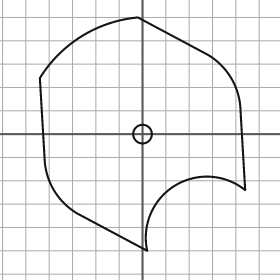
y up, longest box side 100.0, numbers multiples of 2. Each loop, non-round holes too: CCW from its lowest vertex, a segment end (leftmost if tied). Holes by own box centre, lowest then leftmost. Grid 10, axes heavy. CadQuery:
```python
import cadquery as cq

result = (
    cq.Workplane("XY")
    .moveTo(2.0, -50.0)
    .threePointArc((14.0, -22.0), (44.0, -24.0))
    .lineTo(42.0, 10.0)
    .threePointArc((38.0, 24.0), (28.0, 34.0))
    .lineTo(-2.0, 50.0)
    .threePointArc((-26.0, 42.0), (-44.0, 24.0))
    .lineTo(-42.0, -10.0)
    .threePointArc((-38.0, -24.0), (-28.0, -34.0))
    .close()
    .moveTo(0.0, 0.0)
    .circle(4.0)
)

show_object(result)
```